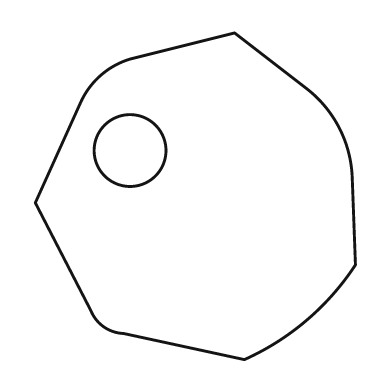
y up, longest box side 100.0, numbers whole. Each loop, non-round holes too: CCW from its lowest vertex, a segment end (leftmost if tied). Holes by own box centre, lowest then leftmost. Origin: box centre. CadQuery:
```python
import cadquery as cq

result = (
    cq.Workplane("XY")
    .moveTo(15.0, -50.0)
    .threePointArc((34.0, -38.0), (49.0, -21.0))
    .lineTo(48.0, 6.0)
    .threePointArc((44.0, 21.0), (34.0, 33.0))
    .lineTo(12.0, 50.0)
    .lineTo(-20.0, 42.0)
    .threePointArc((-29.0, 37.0), (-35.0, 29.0))
    .lineTo(-49.0, -2.0)
    .lineTo(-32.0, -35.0)
    .threePointArc((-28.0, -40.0), (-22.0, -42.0))
    .close()
    .moveTo(-20.0, 14.0)
    .circle(11.0)
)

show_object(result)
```